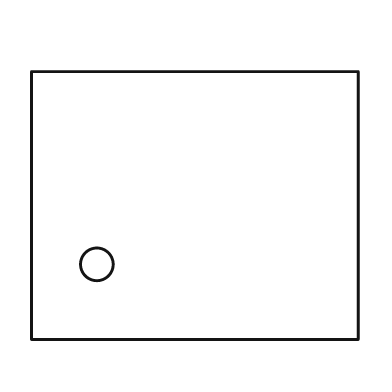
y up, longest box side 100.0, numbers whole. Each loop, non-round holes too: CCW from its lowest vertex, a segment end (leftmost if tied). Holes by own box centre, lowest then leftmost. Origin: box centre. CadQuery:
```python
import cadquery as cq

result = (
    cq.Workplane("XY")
    .moveTo(-50.0, -41.0)
    .lineTo(50.0, -41.0)
    .lineTo(50.0, 41.0)
    .lineTo(-50.0, 41.0)
    .close()
    .moveTo(-30.0, -18.0)
    .circle(5.0)
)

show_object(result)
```